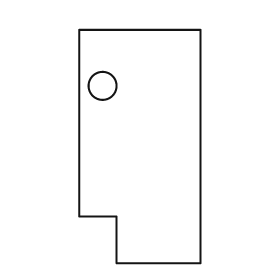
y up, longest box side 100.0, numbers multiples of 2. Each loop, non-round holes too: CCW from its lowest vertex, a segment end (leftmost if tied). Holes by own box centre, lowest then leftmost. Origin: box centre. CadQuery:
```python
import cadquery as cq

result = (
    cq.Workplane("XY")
    .moveTo(-10.0, -50.0)
    .lineTo(26.0, -50.0)
    .lineTo(26.0, 50.0)
    .lineTo(-26.0, 50.0)
    .lineTo(-26.0, -30.0)
    .lineTo(-10.0, -30.0)
    .close()
    .moveTo(-16.0, 26.0)
    .circle(6.0)
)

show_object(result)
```